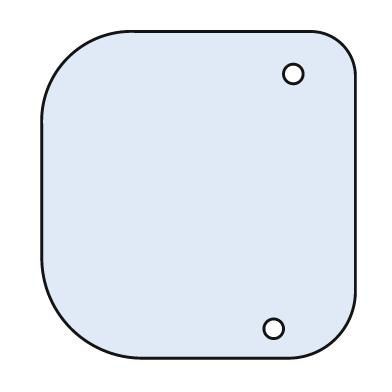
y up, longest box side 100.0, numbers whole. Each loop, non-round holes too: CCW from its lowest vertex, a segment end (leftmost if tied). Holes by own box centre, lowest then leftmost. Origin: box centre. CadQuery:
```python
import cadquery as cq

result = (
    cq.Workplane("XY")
    .moveTo(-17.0, -50.0)
    .lineTo(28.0, -50.0)
    .threePointArc((42.0, -44.0), (48.0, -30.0))
    .lineTo(48.0, 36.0)
    .threePointArc((44.0, 46.0), (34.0, 50.0))
    .lineTo(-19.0, 50.0)
    .threePointArc((-40.0, 42.0), (-48.0, 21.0))
    .lineTo(-48.0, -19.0)
    .threePointArc((-39.0, -41.0), (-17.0, -50.0))
    .close()
    .moveTo(23.0, -41.0)
    .circle(3.0)
    .moveTo(29.0, 37.0)
    .circle(3.0)
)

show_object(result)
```